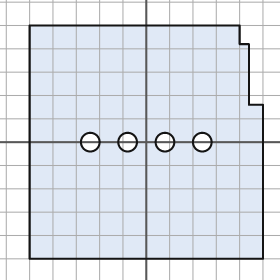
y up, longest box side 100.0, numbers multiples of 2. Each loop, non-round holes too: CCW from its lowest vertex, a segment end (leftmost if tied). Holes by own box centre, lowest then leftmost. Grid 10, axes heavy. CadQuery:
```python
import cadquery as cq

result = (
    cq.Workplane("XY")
    .moveTo(-50.0, -50.0)
    .lineTo(50.0, -50.0)
    .lineTo(50.0, 16.0)
    .lineTo(44.0, 16.0)
    .lineTo(44.0, 42.0)
    .lineTo(40.0, 42.0)
    .lineTo(40.0, 50.0)
    .lineTo(-50.0, 50.0)
    .close()
    .moveTo(-24.0, 0.0)
    .circle(4.0)
    .moveTo(-8.0, 0.0)
    .circle(4.0)
    .moveTo(8.0, 0.0)
    .circle(4.0)
    .moveTo(24.0, 0.0)
    .circle(4.0)
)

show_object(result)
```